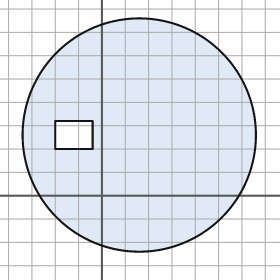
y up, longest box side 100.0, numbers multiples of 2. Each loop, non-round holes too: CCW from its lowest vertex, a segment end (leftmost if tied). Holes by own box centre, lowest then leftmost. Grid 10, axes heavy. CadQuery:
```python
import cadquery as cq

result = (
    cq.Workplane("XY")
    .moveTo(16.0, 26.0)
    .circle(50.0)
    .moveTo(-20.0, 20.0)
    .lineTo(-4.0, 20.0)
    .lineTo(-4.0, 32.0)
    .lineTo(-20.0, 32.0)
    .close()
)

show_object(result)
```